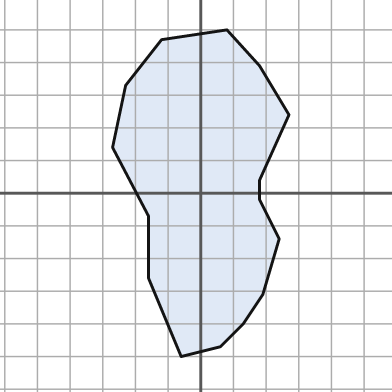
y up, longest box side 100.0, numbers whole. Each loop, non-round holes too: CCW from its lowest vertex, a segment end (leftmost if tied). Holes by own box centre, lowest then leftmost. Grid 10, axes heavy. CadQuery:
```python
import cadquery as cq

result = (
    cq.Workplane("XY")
    .moveTo(-6.0, -50.0)
    .lineTo(6.0, -47.0)
    .lineTo(13.0, -40.0)
    .lineTo(19.0, -31.0)
    .lineTo(24.0, -14.0)
    .lineTo(18.0, -2.0)
    .lineTo(18.0, 4.0)
    .lineTo(27.0, 24.0)
    .lineTo(18.0, 39.0)
    .lineTo(8.0, 50.0)
    .lineTo(-12.0, 47.0)
    .lineTo(-23.0, 33.0)
    .lineTo(-27.0, 14.0)
    .lineTo(-16.0, -7.0)
    .lineTo(-16.0, -26.0)
    .close()
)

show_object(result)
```